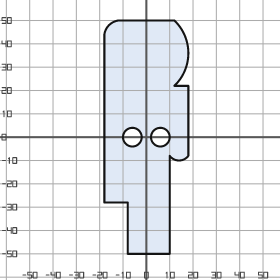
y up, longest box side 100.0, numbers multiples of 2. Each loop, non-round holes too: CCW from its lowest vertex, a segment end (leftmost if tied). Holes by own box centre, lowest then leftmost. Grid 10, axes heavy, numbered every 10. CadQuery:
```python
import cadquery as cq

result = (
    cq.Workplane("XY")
    .moveTo(-8.0, -50.0)
    .lineTo(10.0, -50.0)
    .lineTo(10.0, -8.0)
    .threePointArc((14.0, -10.0), (18.0, -8.0))
    .lineTo(18.0, 22.0)
    .lineTo(12.0, 22.0)
    .threePointArc((18.0, 36.0), (12.0, 50.0))
    .lineTo(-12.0, 50.0)
    .threePointArc((-16.0, 48.0), (-18.0, 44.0))
    .lineTo(-18.0, -28.0)
    .lineTo(-8.0, -28.0)
    .close()
    .moveTo(-6.0, 0.0)
    .circle(4.0)
    .moveTo(6.0, 0.0)
    .circle(4.0)
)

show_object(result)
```